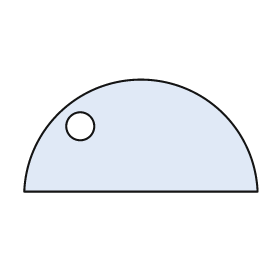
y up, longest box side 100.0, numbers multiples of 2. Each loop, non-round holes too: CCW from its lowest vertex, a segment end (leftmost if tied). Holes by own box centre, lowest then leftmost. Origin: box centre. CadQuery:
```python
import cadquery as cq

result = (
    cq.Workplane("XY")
    .moveTo(-50.0, -24.0)
    .lineTo(50.0, -24.0)
    .threePointArc((0.0, 24.0), (-50.0, -24.0))
    .close()
    .moveTo(-26.0, 4.0)
    .circle(6.0)
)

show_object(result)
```